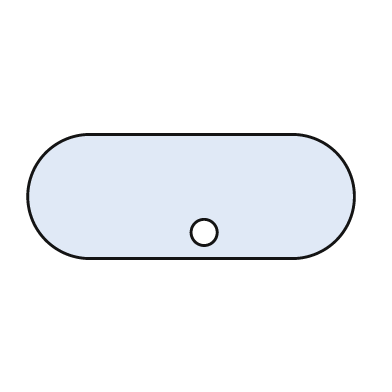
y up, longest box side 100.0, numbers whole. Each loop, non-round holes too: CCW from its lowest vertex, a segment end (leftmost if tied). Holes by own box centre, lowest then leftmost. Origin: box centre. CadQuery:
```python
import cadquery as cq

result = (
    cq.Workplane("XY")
    .moveTo(-31.0, -19.0)
    .lineTo(31.0, -19.0)
    .threePointArc((50.0, 0.0), (31.0, 19.0))
    .lineTo(-31.0, 19.0)
    .threePointArc((-50.0, 0.0), (-31.0, -19.0))
    .close()
    .moveTo(4.0, -11.0)
    .circle(4.0)
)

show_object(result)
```